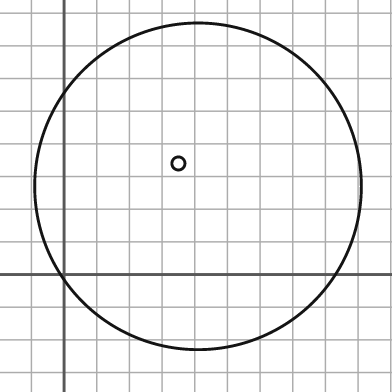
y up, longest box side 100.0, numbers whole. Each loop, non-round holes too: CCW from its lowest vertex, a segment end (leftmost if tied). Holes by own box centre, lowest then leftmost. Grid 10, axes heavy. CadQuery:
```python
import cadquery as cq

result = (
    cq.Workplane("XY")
    .moveTo(41.0, 27.0)
    .circle(50.0)
    .moveTo(35.0, 34.0)
    .circle(2.0)
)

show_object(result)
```